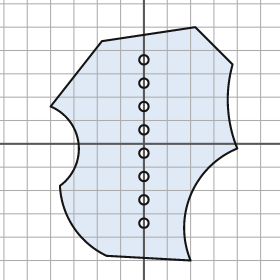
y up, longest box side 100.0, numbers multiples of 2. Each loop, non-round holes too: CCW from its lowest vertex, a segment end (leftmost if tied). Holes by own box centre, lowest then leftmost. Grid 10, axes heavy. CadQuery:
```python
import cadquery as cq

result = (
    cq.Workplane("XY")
    .moveTo(20.0, -50.0)
    .threePointArc((20.0, -22.0), (40.0, -2.0))
    .threePointArc((36.0, 16.0), (38.0, 34.0))
    .lineTo(22.0, 50.0)
    .lineTo(-18.0, 44.0)
    .lineTo(-40.0, 16.0)
    .threePointArc((-28.0, 0.0), (-36.0, -18.0))
    .threePointArc((-30.0, -36.0), (-16.0, -48.0))
    .close()
    .moveTo(0.0, -34.0)
    .circle(2.0)
    .moveTo(0.0, -24.0)
    .circle(2.0)
    .moveTo(0.0, -14.0)
    .circle(2.0)
    .moveTo(0.0, -4.0)
    .circle(2.0)
    .moveTo(0.0, 6.0)
    .circle(2.0)
    .moveTo(0.0, 16.0)
    .circle(2.0)
    .moveTo(0.0, 26.0)
    .circle(2.0)
    .moveTo(0.0, 36.0)
    .circle(2.0)
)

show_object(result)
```